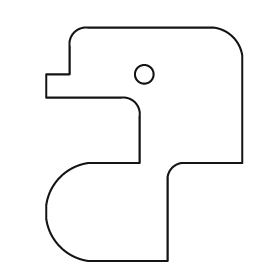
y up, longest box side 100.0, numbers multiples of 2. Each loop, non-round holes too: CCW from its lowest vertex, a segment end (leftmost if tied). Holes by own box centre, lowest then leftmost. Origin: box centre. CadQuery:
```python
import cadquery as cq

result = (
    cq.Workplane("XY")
    .moveTo(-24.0, -50.0)
    .lineTo(10.0, -50.0)
    .lineTo(10.0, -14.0)
    .threePointArc((12.0, -10.0), (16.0, -8.0))
    .lineTo(42.0, -8.0)
    .lineTo(42.0, 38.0)
    .threePointArc((38.0, 46.0), (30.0, 50.0))
    .lineTo(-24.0, 50.0)
    .threePointArc((-30.0, 48.0), (-32.0, 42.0))
    .lineTo(-32.0, 30.0)
    .lineTo(-42.0, 30.0)
    .lineTo(-42.0, 20.0)
    .lineTo(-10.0, 20.0)
    .threePointArc((-4.0, 18.0), (-2.0, 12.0))
    .lineTo(-2.0, -8.0)
    .lineTo(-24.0, -8.0)
    .threePointArc((-36.0, -14.0), (-42.0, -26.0))
    .lineTo(-42.0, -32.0)
    .threePointArc((-36.0, -44.0), (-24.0, -50.0))
    .close()
    .moveTo(0.0, 30.0)
    .circle(4.0)
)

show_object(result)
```